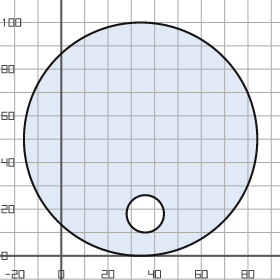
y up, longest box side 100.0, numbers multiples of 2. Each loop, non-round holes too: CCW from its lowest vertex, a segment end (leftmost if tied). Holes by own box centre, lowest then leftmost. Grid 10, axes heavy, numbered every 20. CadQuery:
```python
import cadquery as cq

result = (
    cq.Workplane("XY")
    .moveTo(34.0, 50.0)
    .circle(50.0)
    .moveTo(36.0, 18.0)
    .circle(8.0)
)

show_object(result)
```